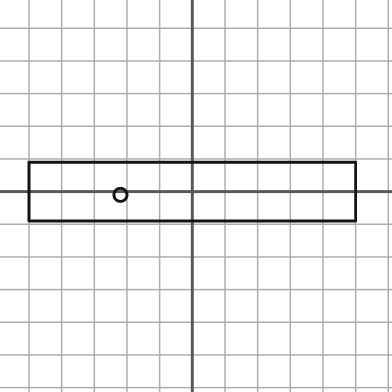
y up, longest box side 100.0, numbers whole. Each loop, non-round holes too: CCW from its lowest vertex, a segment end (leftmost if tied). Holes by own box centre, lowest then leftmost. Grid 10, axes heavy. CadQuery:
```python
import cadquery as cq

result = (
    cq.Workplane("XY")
    .moveTo(-50.0, -9.0)
    .lineTo(50.0, -9.0)
    .lineTo(50.0, 9.0)
    .lineTo(-50.0, 9.0)
    .close()
    .moveTo(-22.0, -1.0)
    .circle(2.0)
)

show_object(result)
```